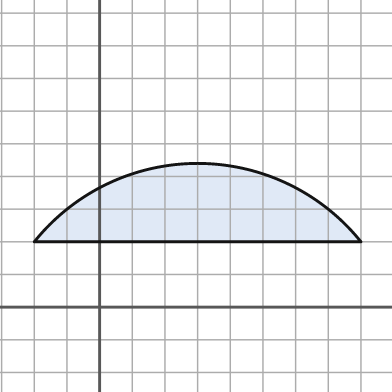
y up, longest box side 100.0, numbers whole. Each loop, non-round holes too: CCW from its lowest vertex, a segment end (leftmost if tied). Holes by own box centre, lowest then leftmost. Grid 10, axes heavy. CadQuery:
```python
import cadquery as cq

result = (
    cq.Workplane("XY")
    .moveTo(-20.0, 20.0)
    .lineTo(80.0, 20.0)
    .threePointArc((30.0, 44.0), (-20.0, 20.0))
    .close()
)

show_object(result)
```